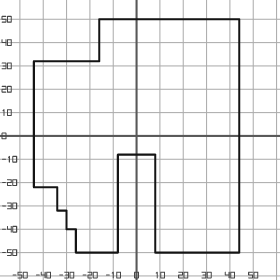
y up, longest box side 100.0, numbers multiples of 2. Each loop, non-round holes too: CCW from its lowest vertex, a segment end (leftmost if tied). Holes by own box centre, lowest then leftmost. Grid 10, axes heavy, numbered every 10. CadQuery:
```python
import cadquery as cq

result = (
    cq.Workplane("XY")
    .moveTo(-26.0, -50.0)
    .lineTo(-8.0, -50.0)
    .lineTo(-8.0, -8.0)
    .lineTo(8.0, -8.0)
    .lineTo(8.0, -50.0)
    .lineTo(44.0, -50.0)
    .lineTo(44.0, 50.0)
    .lineTo(-16.0, 50.0)
    .lineTo(-16.0, 32.0)
    .lineTo(-44.0, 32.0)
    .lineTo(-44.0, -22.0)
    .lineTo(-34.0, -22.0)
    .lineTo(-34.0, -32.0)
    .lineTo(-30.0, -32.0)
    .lineTo(-30.0, -40.0)
    .lineTo(-26.0, -40.0)
    .close()
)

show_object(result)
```